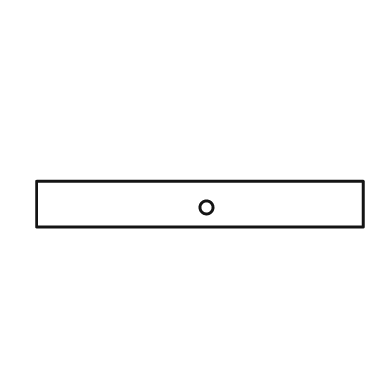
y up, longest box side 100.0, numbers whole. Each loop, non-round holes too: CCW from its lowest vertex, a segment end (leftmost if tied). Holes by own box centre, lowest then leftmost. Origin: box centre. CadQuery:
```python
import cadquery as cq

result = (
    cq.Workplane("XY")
    .moveTo(-50.0, -7.0)
    .lineTo(50.0, -7.0)
    .lineTo(50.0, 7.0)
    .lineTo(-50.0, 7.0)
    .close()
    .moveTo(2.0, -1.0)
    .circle(2.0)
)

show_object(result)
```